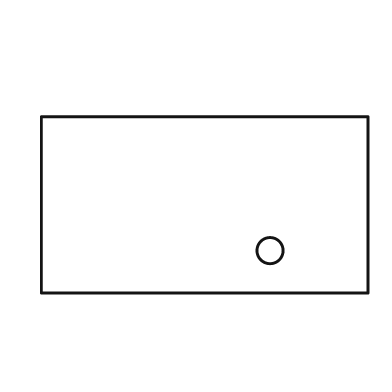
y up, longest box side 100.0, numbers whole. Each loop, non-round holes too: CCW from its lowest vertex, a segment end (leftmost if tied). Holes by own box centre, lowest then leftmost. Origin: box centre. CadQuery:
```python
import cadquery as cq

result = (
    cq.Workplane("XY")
    .moveTo(-50.0, -27.0)
    .lineTo(50.0, -27.0)
    .lineTo(50.0, 27.0)
    .lineTo(-50.0, 27.0)
    .close()
    .moveTo(20.0, -14.0)
    .circle(4.0)
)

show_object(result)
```